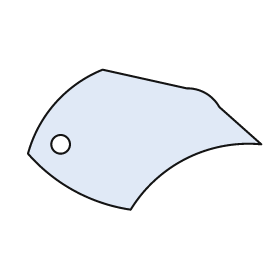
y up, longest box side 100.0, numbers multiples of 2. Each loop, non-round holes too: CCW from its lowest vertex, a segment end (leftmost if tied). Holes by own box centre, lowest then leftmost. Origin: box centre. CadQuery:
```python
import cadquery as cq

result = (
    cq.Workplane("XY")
    .moveTo(-6.0, -30.0)
    .threePointArc((18.0, -8.0), (50.0, -2.0))
    .lineTo(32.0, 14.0)
    .threePointArc((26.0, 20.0), (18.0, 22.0))
    .lineTo(-18.0, 30.0)
    .threePointArc((-38.0, 16.0), (-50.0, -6.0))
    .threePointArc((-30.0, -22.0), (-6.0, -30.0))
    .close()
    .moveTo(-36.0, -2.0)
    .circle(4.0)
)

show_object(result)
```